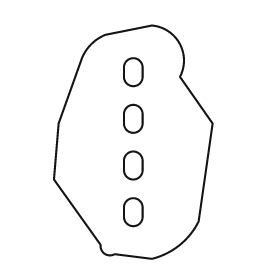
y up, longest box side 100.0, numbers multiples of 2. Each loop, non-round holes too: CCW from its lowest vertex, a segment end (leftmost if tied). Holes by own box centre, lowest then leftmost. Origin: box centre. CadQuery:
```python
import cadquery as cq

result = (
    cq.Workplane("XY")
    .moveTo(8.0, -50.0)
    .threePointArc((20.0, -44.0), (28.0, -34.0))
    .lineTo(34.0, 8.0)
    .lineTo(20.0, 28.0)
    .threePointArc((20.0, 42.0), (8.0, 50.0))
    .lineTo(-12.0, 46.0)
    .threePointArc((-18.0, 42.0), (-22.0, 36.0))
    .lineTo(-32.0, 8.0)
    .lineTo(-34.0, -16.0)
    .lineTo(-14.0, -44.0)
    .threePointArc((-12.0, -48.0), (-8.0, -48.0))
    .close()
    .moveTo(-4.0, -32.0)
    .threePointArc((0.0, -36.0), (4.0, -32.0))
    .lineTo(4.0, -28.0)
    .threePointArc((0.0, -24.0), (-4.0, -28.0))
    .close()
    .moveTo(-4.0, -12.0)
    .threePointArc((0.0, -16.0), (4.0, -12.0))
    .lineTo(4.0, -8.0)
    .threePointArc((0.0, -4.0), (-4.0, -8.0))
    .close()
    .moveTo(-4.0, 8.0)
    .threePointArc((0.0, 4.0), (4.0, 8.0))
    .lineTo(4.0, 12.0)
    .threePointArc((0.0, 16.0), (-4.0, 12.0))
    .close()
    .moveTo(-4.0, 28.0)
    .threePointArc((0.0, 24.0), (4.0, 28.0))
    .lineTo(4.0, 32.0)
    .threePointArc((0.0, 36.0), (-4.0, 32.0))
    .close()
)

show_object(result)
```